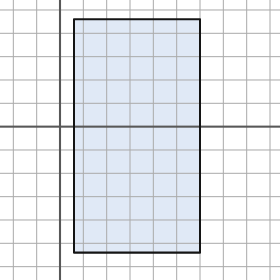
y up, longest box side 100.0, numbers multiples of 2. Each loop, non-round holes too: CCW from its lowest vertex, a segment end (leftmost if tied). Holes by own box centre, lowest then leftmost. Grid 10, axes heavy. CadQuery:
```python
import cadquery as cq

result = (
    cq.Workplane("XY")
    .moveTo(6.0, -54.0)
    .lineTo(60.0, -54.0)
    .lineTo(60.0, 46.0)
    .lineTo(6.0, 46.0)
    .close()
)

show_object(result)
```